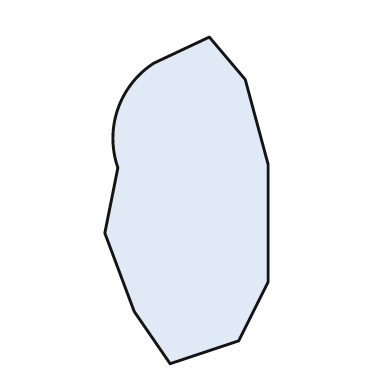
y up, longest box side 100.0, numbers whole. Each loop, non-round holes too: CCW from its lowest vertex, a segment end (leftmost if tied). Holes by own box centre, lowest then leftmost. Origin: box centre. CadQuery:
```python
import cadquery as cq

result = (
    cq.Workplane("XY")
    .moveTo(-5.0, -50.0)
    .lineTo(16.0, -43.0)
    .lineTo(25.0, -25.0)
    .lineTo(25.0, 11.0)
    .lineTo(18.0, 37.0)
    .lineTo(7.0, 50.0)
    .lineTo(-10.0, 42.0)
    .threePointArc((-21.0, 28.0), (-21.0, 10.0))
    .lineTo(-25.0, -10.0)
    .lineTo(-16.0, -34.0)
    .close()
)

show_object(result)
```